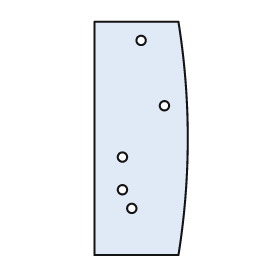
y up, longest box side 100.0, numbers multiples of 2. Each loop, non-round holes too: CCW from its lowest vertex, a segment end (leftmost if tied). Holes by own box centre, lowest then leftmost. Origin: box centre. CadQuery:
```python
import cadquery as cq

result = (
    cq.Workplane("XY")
    .moveTo(-20.0, -50.0)
    .lineTo(16.0, -50.0)
    .threePointArc((20.0, 0.0), (16.0, 50.0))
    .lineTo(-20.0, 50.0)
    .close()
    .moveTo(-4.0, -30.0)
    .circle(2.0)
    .moveTo(-8.0, -22.0)
    .circle(2.0)
    .moveTo(-8.0, -8.0)
    .circle(2.0)
    .moveTo(10.0, 14.0)
    .circle(2.0)
    .moveTo(0.0, 42.0)
    .circle(2.0)
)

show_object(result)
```